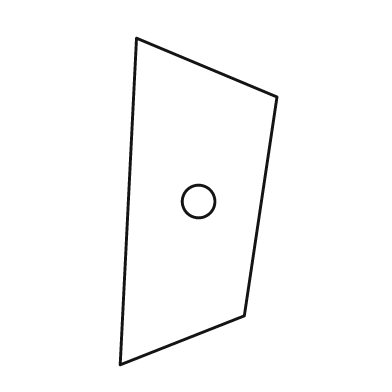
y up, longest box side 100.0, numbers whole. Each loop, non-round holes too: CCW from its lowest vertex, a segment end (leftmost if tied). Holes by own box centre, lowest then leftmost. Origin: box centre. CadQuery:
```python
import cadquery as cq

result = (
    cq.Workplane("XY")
    .moveTo(-24.0, -50.0)
    .lineTo(14.0, -35.0)
    .lineTo(24.0, 32.0)
    .lineTo(-19.0, 50.0)
    .close()
    .moveTo(0.0, 0.0)
    .circle(5.0)
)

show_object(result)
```